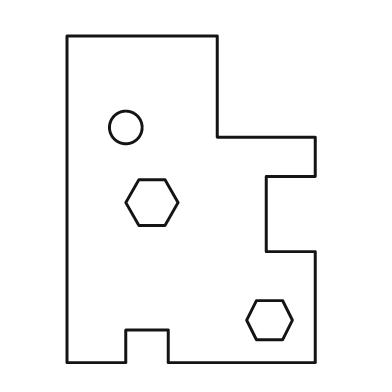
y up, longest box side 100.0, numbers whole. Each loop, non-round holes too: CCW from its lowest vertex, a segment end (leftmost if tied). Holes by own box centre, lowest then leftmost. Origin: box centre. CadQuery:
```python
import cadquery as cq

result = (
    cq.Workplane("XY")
    .moveTo(-38.0, -50.0)
    .lineTo(-20.0, -50.0)
    .lineTo(-20.0, -40.0)
    .lineTo(-7.0, -40.0)
    .lineTo(-7.0, -50.0)
    .lineTo(38.0, -50.0)
    .lineTo(38.0, -16.0)
    .lineTo(23.0, -16.0)
    .lineTo(23.0, 7.0)
    .lineTo(38.0, 7.0)
    .lineTo(38.0, 19.0)
    .lineTo(8.0, 19.0)
    .lineTo(8.0, 50.0)
    .lineTo(-38.0, 50.0)
    .close()
    .moveTo(20.0, -43.0)
    .lineTo(28.0, -43.0)
    .lineTo(31.0, -37.0)
    .lineTo(28.0, -31.0)
    .lineTo(20.0, -31.0)
    .lineTo(17.0, -37.0)
    .close()
    .moveTo(-16.0, -8.0)
    .lineTo(-8.0, -8.0)
    .lineTo(-4.0, -1.0)
    .lineTo(-8.0, 6.0)
    .lineTo(-16.0, 6.0)
    .lineTo(-20.0, -1.0)
    .close()
    .moveTo(-20.0, 22.0)
    .circle(5.0)
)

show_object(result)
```